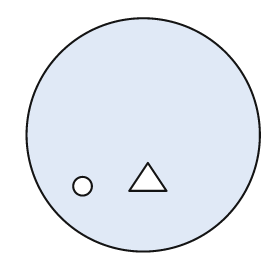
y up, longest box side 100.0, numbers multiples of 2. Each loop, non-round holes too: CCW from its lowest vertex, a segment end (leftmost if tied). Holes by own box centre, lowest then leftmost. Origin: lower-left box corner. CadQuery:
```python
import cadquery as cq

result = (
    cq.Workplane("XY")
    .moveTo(50.0, 50.0)
    .circle(50.0)
    .moveTo(24.0, 28.0)
    .circle(4.0)
    .moveTo(44.0, 26.0)
    .lineTo(60.0, 26.0)
    .lineTo(52.0, 38.0)
    .close()
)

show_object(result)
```